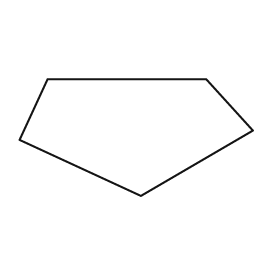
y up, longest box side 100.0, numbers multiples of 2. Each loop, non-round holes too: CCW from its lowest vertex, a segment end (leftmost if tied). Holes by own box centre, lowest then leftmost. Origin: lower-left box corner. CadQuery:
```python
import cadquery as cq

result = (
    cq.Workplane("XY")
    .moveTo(52.0, 0.0)
    .lineTo(100.0, 28.0)
    .lineTo(80.0, 50.0)
    .lineTo(12.0, 50.0)
    .lineTo(0.0, 24.0)
    .close()
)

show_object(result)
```